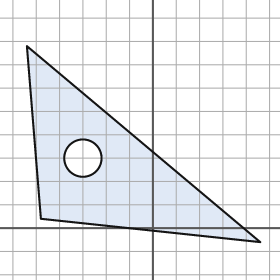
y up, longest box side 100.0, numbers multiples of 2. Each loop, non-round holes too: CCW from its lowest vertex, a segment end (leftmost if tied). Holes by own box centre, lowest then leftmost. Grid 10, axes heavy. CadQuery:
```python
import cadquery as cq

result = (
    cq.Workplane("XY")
    .moveTo(46.0, -6.0)
    .lineTo(-54.0, 78.0)
    .lineTo(-48.0, 4.0)
    .close()
    .moveTo(-30.0, 30.0)
    .circle(8.0)
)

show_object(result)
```